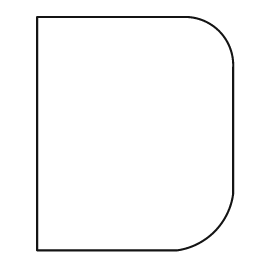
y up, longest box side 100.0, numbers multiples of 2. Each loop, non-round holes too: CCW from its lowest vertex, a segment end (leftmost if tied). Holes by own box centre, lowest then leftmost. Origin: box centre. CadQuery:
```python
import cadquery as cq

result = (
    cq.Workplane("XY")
    .moveTo(-42.0, -50.0)
    .lineTo(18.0, -50.0)
    .threePointArc((34.0, -42.0), (42.0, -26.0))
    .lineTo(42.0, 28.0)
    .threePointArc((36.0, 44.0), (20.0, 50.0))
    .lineTo(-42.0, 50.0)
    .close()
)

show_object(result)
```